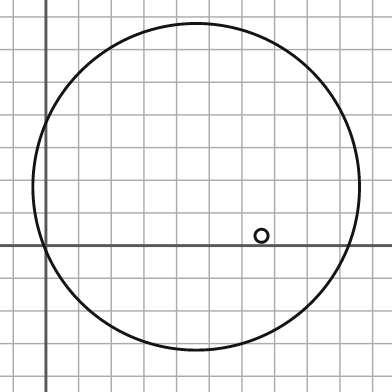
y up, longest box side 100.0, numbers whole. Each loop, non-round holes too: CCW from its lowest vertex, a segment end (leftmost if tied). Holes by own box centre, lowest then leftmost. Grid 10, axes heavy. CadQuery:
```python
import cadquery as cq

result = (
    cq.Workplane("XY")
    .moveTo(46.0, 18.0)
    .circle(50.0)
    .moveTo(66.0, 3.0)
    .circle(2.0)
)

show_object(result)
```